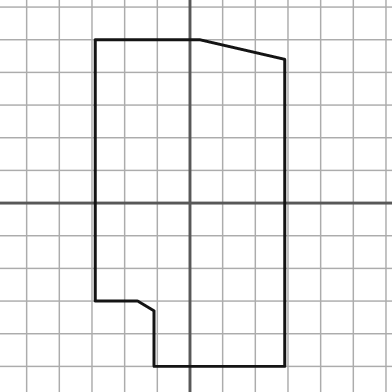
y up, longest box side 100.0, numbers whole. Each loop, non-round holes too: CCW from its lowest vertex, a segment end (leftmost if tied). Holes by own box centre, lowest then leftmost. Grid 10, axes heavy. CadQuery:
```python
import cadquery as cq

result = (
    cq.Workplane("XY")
    .moveTo(-11.0, -50.0)
    .lineTo(29.0, -50.0)
    .lineTo(29.0, 44.0)
    .lineTo(3.0, 50.0)
    .lineTo(-29.0, 50.0)
    .lineTo(-29.0, -30.0)
    .lineTo(-16.0, -30.0)
    .lineTo(-11.0, -33.0)
    .close()
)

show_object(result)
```